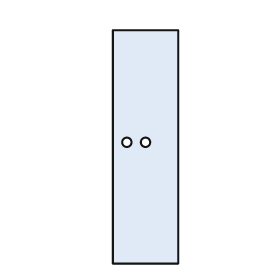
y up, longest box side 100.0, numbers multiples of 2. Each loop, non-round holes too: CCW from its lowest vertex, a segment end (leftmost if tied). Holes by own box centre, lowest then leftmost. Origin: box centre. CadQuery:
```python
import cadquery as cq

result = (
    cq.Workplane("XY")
    .moveTo(-14.0, -50.0)
    .lineTo(14.0, -50.0)
    .lineTo(14.0, 50.0)
    .lineTo(-14.0, 50.0)
    .close()
    .moveTo(-8.0, 2.0)
    .circle(2.0)
    .moveTo(0.0, 2.0)
    .circle(2.0)
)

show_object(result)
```